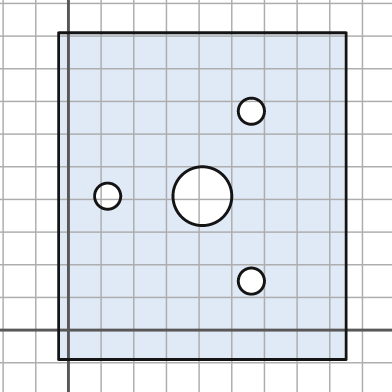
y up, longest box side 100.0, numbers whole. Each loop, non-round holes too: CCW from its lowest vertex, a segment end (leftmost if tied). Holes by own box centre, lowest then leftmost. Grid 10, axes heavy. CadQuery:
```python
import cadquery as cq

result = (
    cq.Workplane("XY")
    .moveTo(-3.0, -9.0)
    .lineTo(85.0, -9.0)
    .lineTo(85.0, 91.0)
    .lineTo(-3.0, 91.0)
    .close()
    .moveTo(56.0, 15.0)
    .circle(4.0)
    .moveTo(12.0, 41.0)
    .circle(4.0)
    .moveTo(41.0, 41.0)
    .circle(9.0)
    .moveTo(56.0, 67.0)
    .circle(4.0)
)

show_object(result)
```